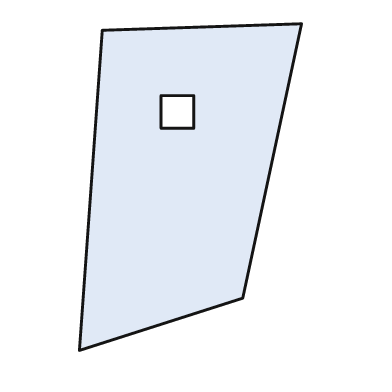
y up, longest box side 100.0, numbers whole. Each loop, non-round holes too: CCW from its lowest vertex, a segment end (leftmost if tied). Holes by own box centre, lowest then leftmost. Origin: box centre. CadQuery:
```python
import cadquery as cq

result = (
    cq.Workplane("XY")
    .moveTo(-34.0, -50.0)
    .lineTo(16.0, -34.0)
    .lineTo(34.0, 50.0)
    .lineTo(-27.0, 48.0)
    .close()
    .moveTo(-9.0, 18.0)
    .lineTo(1.0, 18.0)
    .lineTo(1.0, 28.0)
    .lineTo(-9.0, 28.0)
    .close()
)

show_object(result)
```